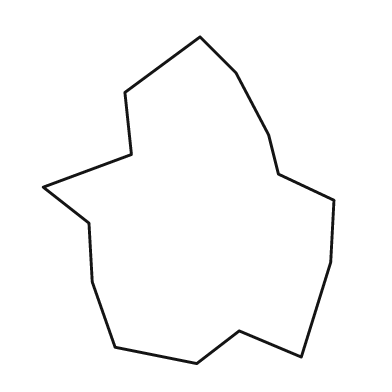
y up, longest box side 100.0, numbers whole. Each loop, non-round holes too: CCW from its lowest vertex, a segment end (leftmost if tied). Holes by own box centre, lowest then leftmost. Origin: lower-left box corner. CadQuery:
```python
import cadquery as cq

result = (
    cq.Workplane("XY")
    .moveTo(47.0, 0.0)
    .lineTo(60.0, 10.0)
    .lineTo(79.0, 2.0)
    .lineTo(88.0, 31.0)
    .lineTo(89.0, 50.0)
    .lineTo(72.0, 58.0)
    .lineTo(69.0, 70.0)
    .lineTo(59.0, 89.0)
    .lineTo(48.0, 100.0)
    .lineTo(25.0, 83.0)
    .lineTo(27.0, 64.0)
    .lineTo(0.0, 54.0)
    .lineTo(14.0, 43.0)
    .lineTo(15.0, 25.0)
    .lineTo(22.0, 5.0)
    .close()
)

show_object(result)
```